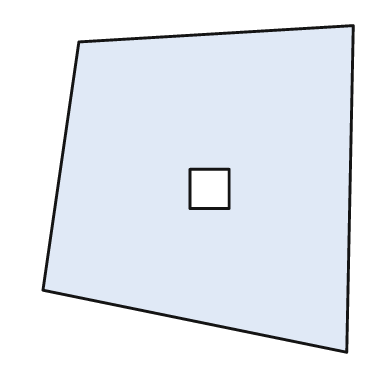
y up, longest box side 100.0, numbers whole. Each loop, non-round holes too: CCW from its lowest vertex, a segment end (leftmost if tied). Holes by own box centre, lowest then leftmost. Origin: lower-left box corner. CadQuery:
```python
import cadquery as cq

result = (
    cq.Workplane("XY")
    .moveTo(93.0, 0.0)
    .lineTo(95.0, 100.0)
    .lineTo(11.0, 95.0)
    .lineTo(0.0, 19.0)
    .close()
    .moveTo(45.0, 44.0)
    .lineTo(57.0, 44.0)
    .lineTo(57.0, 56.0)
    .lineTo(45.0, 56.0)
    .close()
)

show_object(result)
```